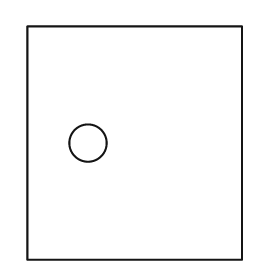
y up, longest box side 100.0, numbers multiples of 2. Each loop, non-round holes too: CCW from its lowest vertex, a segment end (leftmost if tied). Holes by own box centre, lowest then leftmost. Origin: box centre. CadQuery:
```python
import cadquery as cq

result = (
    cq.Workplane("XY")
    .moveTo(-46.0, -50.0)
    .lineTo(46.0, -50.0)
    .lineTo(46.0, 50.0)
    .lineTo(-46.0, 50.0)
    .close()
    .moveTo(-20.0, 0.0)
    .circle(8.0)
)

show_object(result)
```